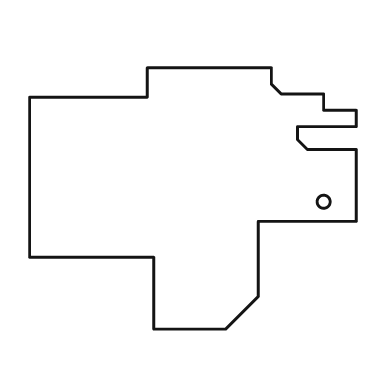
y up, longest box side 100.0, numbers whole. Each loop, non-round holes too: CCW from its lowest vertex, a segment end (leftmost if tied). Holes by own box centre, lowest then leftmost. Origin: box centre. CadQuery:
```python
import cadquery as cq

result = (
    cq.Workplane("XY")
    .moveTo(-12.0, -40.0)
    .lineTo(10.0, -40.0)
    .lineTo(20.0, -30.0)
    .lineTo(20.0, -7.0)
    .lineTo(50.0, -7.0)
    .lineTo(50.0, 15.0)
    .lineTo(35.0, 15.0)
    .lineTo(32.0, 18.0)
    .lineTo(32.0, 22.0)
    .lineTo(50.0, 22.0)
    .lineTo(50.0, 27.0)
    .lineTo(40.0, 27.0)
    .lineTo(40.0, 32.0)
    .lineTo(27.0, 32.0)
    .lineTo(24.0, 35.0)
    .lineTo(24.0, 40.0)
    .lineTo(-14.0, 40.0)
    .lineTo(-14.0, 31.0)
    .lineTo(-50.0, 31.0)
    .lineTo(-50.0, -18.0)
    .lineTo(-12.0, -18.0)
    .close()
    .moveTo(40.0, -1.0)
    .circle(2.0)
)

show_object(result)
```